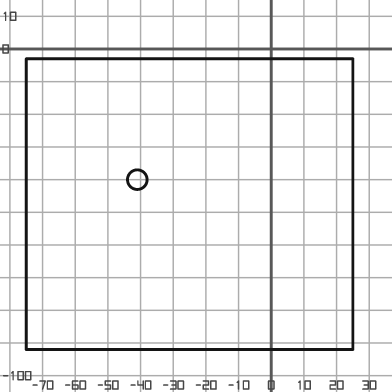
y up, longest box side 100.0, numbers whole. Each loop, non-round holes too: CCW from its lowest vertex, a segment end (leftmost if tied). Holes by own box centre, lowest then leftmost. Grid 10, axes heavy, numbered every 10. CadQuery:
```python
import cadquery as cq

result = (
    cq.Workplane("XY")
    .moveTo(-75.0, -92.0)
    .lineTo(25.0, -92.0)
    .lineTo(25.0, -3.0)
    .lineTo(-75.0, -3.0)
    .close()
    .moveTo(-41.0, -40.0)
    .circle(3.0)
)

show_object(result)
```